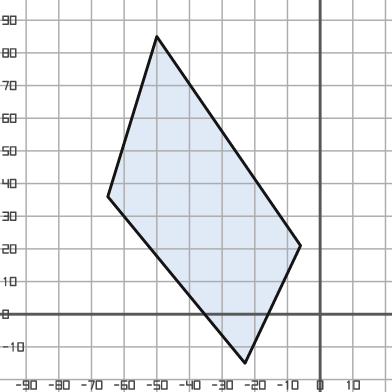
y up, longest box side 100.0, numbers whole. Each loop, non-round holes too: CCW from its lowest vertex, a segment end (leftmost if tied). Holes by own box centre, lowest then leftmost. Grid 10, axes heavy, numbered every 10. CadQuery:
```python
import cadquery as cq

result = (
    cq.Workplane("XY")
    .moveTo(-23.0, -15.0)
    .lineTo(-6.0, 21.0)
    .lineTo(-50.0, 85.0)
    .lineTo(-65.0, 36.0)
    .close()
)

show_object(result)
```